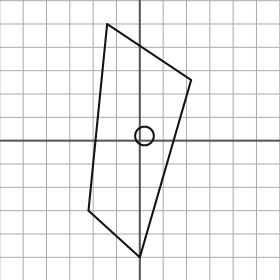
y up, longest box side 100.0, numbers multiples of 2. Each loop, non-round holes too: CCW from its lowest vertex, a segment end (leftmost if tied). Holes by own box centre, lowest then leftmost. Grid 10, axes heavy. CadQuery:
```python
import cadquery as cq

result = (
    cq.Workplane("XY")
    .moveTo(0.0, -50.0)
    .lineTo(22.0, 26.0)
    .lineTo(-14.0, 50.0)
    .lineTo(-22.0, -30.0)
    .close()
    .moveTo(2.0, 2.0)
    .circle(4.0)
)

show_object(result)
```